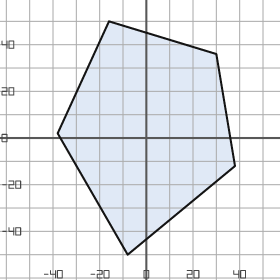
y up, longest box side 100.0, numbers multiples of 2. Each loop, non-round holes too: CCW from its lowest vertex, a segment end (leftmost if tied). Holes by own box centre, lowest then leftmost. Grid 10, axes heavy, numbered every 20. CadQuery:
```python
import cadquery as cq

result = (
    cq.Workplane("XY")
    .moveTo(-8.0, -50.0)
    .lineTo(38.0, -12.0)
    .lineTo(30.0, 36.0)
    .lineTo(-16.0, 50.0)
    .lineTo(-38.0, 2.0)
    .close()
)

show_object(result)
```